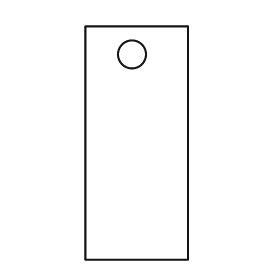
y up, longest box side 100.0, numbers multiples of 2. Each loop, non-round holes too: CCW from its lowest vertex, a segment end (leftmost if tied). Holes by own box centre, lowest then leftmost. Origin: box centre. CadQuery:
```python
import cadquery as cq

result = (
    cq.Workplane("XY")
    .moveTo(-22.0, -50.0)
    .lineTo(22.0, -50.0)
    .lineTo(22.0, 50.0)
    .lineTo(-22.0, 50.0)
    .close()
    .moveTo(-2.0, 38.0)
    .circle(6.0)
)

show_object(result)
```